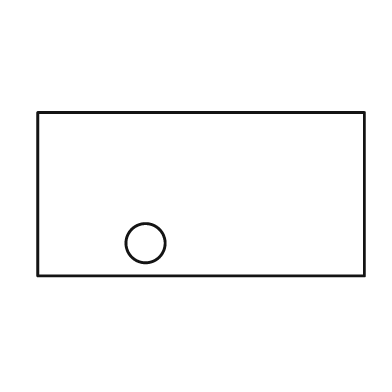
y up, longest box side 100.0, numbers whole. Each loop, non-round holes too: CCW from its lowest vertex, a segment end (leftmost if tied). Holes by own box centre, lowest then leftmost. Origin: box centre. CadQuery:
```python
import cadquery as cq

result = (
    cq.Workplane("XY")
    .moveTo(-50.0, -25.0)
    .lineTo(50.0, -25.0)
    .lineTo(50.0, 25.0)
    .lineTo(-50.0, 25.0)
    .close()
    .moveTo(-17.0, -15.0)
    .circle(6.0)
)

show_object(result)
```